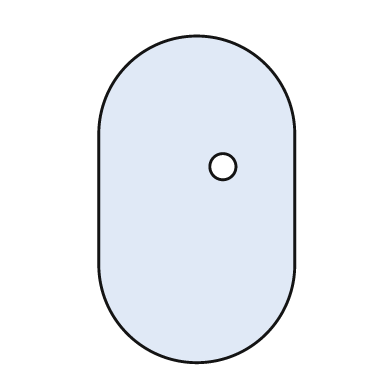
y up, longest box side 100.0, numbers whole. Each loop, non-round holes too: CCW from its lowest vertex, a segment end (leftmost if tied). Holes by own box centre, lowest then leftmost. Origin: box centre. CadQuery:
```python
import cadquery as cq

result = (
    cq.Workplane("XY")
    .moveTo(-30.0, -20.0)
    .threePointArc((0.0, -50.0), (30.0, -20.0))
    .lineTo(30.0, 20.0)
    .threePointArc((0.0, 50.0), (-30.0, 20.0))
    .close()
    .moveTo(8.0, 10.0)
    .circle(4.0)
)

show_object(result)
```